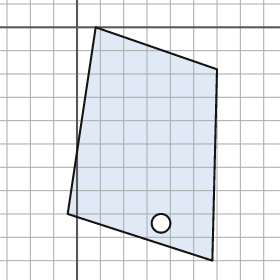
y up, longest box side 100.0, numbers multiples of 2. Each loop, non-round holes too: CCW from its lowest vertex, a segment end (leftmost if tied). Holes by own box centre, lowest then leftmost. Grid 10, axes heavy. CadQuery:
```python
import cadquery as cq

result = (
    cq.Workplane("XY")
    .moveTo(58.0, -100.0)
    .lineTo(60.0, -18.0)
    .lineTo(8.0, 0.0)
    .lineTo(-4.0, -80.0)
    .close()
    .moveTo(36.0, -84.0)
    .circle(4.0)
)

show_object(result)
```